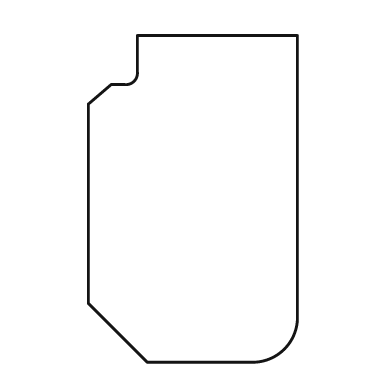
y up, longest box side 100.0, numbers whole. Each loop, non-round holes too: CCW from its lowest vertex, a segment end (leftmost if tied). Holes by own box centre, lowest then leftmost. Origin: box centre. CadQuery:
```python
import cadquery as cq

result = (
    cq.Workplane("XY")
    .moveTo(-14.0, -50.0)
    .lineTo(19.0, -50.0)
    .threePointArc((28.0, -46.0), (32.0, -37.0))
    .lineTo(32.0, 50.0)
    .lineTo(-17.0, 50.0)
    .lineTo(-17.0, 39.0)
    .threePointArc((-18.0, 36.0), (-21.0, 35.0))
    .lineTo(-25.0, 35.0)
    .lineTo(-32.0, 29.0)
    .lineTo(-32.0, -32.0)
    .close()
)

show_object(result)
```